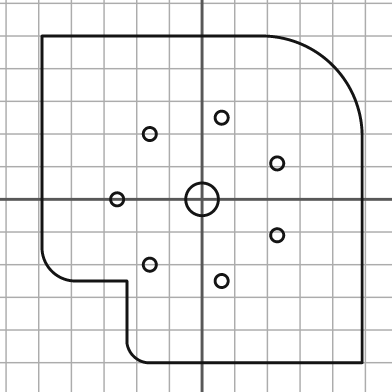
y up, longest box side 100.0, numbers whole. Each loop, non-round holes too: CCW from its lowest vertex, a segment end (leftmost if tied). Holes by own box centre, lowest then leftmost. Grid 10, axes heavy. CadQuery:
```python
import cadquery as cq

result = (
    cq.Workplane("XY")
    .moveTo(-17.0, -50.0)
    .lineTo(49.0, -50.0)
    .lineTo(49.0, 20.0)
    .threePointArc((40.0, 41.0), (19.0, 50.0))
    .lineTo(-49.0, 50.0)
    .lineTo(-49.0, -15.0)
    .threePointArc((-46.0, -22.0), (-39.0, -25.0))
    .lineTo(-23.0, -25.0)
    .lineTo(-23.0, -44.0)
    .threePointArc((-21.0, -48.0), (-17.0, -50.0))
    .close()
    .moveTo(6.0, -25.0)
    .circle(2.0)
    .moveTo(-16.0, -20.0)
    .circle(2.0)
    .moveTo(23.0, -11.0)
    .circle(2.0)
    .moveTo(-26.0, 0.0)
    .circle(2.0)
    .moveTo(0.0, 0.0)
    .circle(5.0)
    .moveTo(23.0, 11.0)
    .circle(2.0)
    .moveTo(-16.0, 20.0)
    .circle(2.0)
    .moveTo(6.0, 25.0)
    .circle(2.0)
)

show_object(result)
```